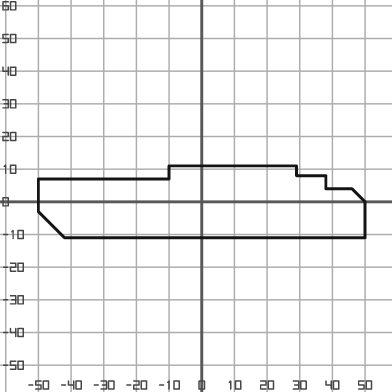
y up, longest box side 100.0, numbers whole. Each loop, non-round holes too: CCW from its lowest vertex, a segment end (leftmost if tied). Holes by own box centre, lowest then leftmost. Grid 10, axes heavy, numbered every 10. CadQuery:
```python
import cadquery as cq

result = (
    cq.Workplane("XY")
    .moveTo(-42.0, -11.0)
    .lineTo(50.0, -11.0)
    .lineTo(50.0, 0.0)
    .lineTo(46.0, 4.0)
    .lineTo(38.0, 4.0)
    .lineTo(38.0, 8.0)
    .lineTo(29.0, 8.0)
    .lineTo(29.0, 11.0)
    .lineTo(-10.0, 11.0)
    .lineTo(-10.0, 7.0)
    .lineTo(-50.0, 7.0)
    .lineTo(-50.0, -3.0)
    .close()
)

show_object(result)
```